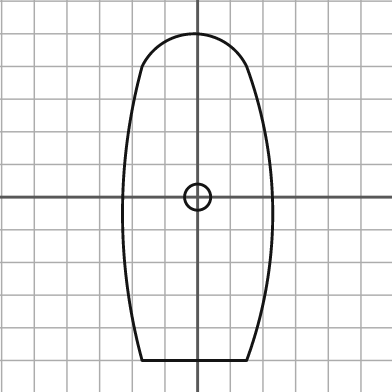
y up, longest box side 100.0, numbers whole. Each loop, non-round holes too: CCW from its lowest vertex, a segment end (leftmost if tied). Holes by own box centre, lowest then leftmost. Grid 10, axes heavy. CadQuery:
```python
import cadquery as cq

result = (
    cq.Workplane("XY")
    .moveTo(-17.0, -50.0)
    .lineTo(15.0, -50.0)
    .threePointArc((23.0, -5.0), (15.0, 40.0))
    .threePointArc((-1.0, 50.0), (-17.0, 40.0))
    .threePointArc((-23.0, -5.0), (-17.0, -50.0))
    .close()
    .moveTo(0.0, 0.0)
    .circle(4.0)
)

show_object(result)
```